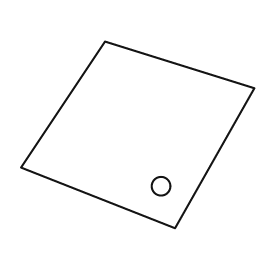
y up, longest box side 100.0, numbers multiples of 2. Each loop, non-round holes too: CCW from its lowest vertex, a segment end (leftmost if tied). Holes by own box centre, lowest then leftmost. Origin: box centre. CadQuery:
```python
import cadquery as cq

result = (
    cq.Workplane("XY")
    .moveTo(16.0, -40.0)
    .lineTo(50.0, 20.0)
    .lineTo(-14.0, 40.0)
    .lineTo(-50.0, -14.0)
    .close()
    .moveTo(10.0, -22.0)
    .circle(4.0)
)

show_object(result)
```